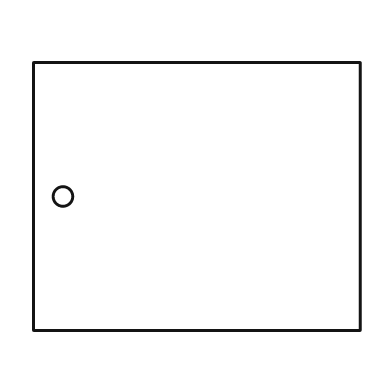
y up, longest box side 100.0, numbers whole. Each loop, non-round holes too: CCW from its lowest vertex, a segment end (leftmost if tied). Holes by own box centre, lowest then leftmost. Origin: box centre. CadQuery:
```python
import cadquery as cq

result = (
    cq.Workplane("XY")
    .moveTo(-50.0, -41.0)
    .lineTo(50.0, -41.0)
    .lineTo(50.0, 41.0)
    .lineTo(-50.0, 41.0)
    .close()
    .moveTo(-41.0, 0.0)
    .circle(3.0)
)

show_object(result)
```